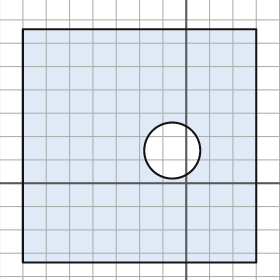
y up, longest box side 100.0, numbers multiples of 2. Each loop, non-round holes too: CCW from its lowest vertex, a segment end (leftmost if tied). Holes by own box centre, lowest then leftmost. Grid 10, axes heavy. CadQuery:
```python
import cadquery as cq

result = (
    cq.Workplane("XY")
    .moveTo(-70.0, -34.0)
    .lineTo(30.0, -34.0)
    .lineTo(30.0, 66.0)
    .lineTo(-70.0, 66.0)
    .close()
    .moveTo(-6.0, 14.0)
    .circle(12.0)
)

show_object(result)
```